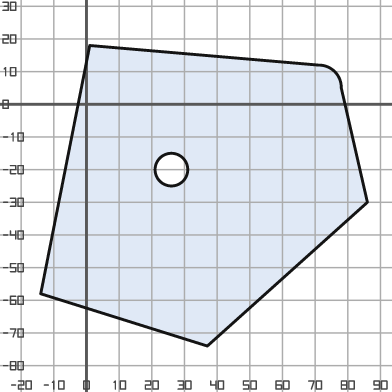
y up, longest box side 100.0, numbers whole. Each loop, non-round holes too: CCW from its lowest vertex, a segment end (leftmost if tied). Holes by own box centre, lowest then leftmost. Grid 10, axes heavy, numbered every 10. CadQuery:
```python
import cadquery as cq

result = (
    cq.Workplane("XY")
    .moveTo(37.0, -74.0)
    .lineTo(86.0, -30.0)
    .lineTo(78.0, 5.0)
    .threePointArc((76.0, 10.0), (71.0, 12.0))
    .lineTo(1.0, 18.0)
    .lineTo(-14.0, -58.0)
    .close()
    .moveTo(26.0, -20.0)
    .circle(5.0)
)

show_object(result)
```